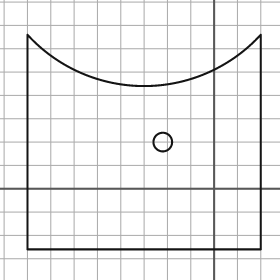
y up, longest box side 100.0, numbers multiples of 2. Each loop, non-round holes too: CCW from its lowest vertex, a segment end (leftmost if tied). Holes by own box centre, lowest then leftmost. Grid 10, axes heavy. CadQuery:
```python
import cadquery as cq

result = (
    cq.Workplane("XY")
    .moveTo(-80.0, -26.0)
    .lineTo(20.0, -26.0)
    .lineTo(20.0, 66.0)
    .threePointArc((-30.0, 44.0), (-80.0, 66.0))
    .close()
    .moveTo(-22.0, 20.0)
    .circle(4.0)
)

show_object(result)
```